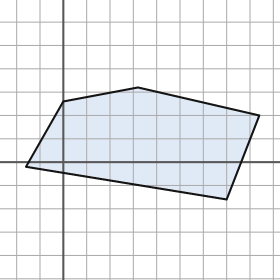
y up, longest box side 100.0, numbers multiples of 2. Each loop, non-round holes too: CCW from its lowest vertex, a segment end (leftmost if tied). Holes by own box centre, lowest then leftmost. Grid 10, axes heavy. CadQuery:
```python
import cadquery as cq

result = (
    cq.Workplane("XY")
    .moveTo(70.0, -16.0)
    .lineTo(84.0, 20.0)
    .lineTo(32.0, 32.0)
    .lineTo(0.0, 26.0)
    .lineTo(-16.0, -2.0)
    .close()
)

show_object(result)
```